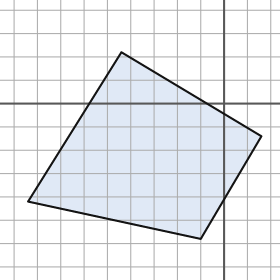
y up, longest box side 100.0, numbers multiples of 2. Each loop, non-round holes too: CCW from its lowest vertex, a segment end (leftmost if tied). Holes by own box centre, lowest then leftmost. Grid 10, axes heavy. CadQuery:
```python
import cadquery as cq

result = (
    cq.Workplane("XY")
    .moveTo(-10.0, -58.0)
    .lineTo(16.0, -14.0)
    .lineTo(-44.0, 22.0)
    .lineTo(-84.0, -42.0)
    .close()
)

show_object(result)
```